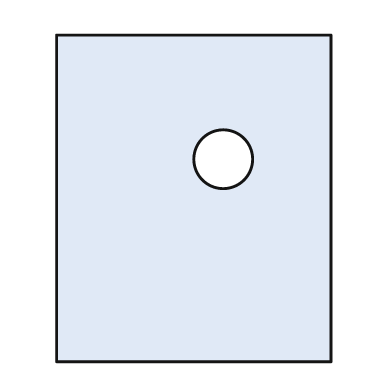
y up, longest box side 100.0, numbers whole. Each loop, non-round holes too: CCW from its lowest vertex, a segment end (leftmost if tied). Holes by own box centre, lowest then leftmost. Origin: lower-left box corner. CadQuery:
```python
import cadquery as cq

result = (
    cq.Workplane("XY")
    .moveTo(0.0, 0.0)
    .lineTo(84.0, 0.0)
    .lineTo(84.0, 100.0)
    .lineTo(0.0, 100.0)
    .close()
    .moveTo(51.0, 62.0)
    .circle(9.0)
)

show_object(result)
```